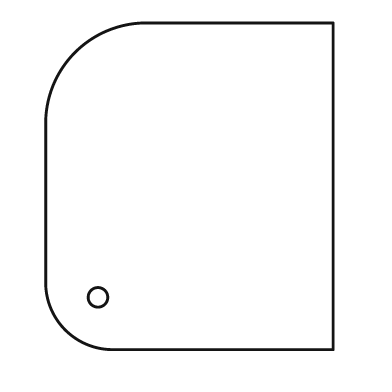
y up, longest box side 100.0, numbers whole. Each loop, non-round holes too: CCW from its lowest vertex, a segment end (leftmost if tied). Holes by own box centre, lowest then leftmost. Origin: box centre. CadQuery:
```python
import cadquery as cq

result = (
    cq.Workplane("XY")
    .moveTo(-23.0, -50.0)
    .lineTo(44.0, -50.0)
    .lineTo(44.0, 50.0)
    .lineTo(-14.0, 50.0)
    .threePointArc((-35.0, 41.0), (-44.0, 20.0))
    .lineTo(-44.0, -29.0)
    .threePointArc((-38.0, -44.0), (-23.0, -50.0))
    .close()
    .moveTo(-28.0, -34.0)
    .circle(3.0)
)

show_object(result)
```